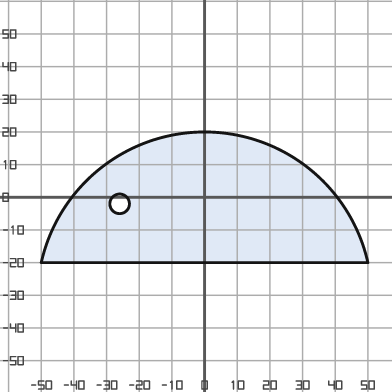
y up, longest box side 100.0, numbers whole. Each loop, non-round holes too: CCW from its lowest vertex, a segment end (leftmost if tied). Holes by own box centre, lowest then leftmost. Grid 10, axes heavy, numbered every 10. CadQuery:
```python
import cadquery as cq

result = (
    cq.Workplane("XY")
    .moveTo(-50.0, -20.0)
    .lineTo(50.0, -20.0)
    .threePointArc((0.0, 20.0), (-50.0, -20.0))
    .close()
    .moveTo(-26.0, -2.0)
    .circle(3.0)
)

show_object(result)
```